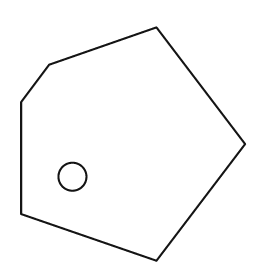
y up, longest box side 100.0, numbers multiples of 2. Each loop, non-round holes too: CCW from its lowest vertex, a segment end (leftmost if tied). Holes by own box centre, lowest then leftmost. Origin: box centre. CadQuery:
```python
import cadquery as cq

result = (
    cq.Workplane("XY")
    .moveTo(10.0, -50.0)
    .lineTo(48.0, 0.0)
    .lineTo(10.0, 50.0)
    .lineTo(-36.0, 34.0)
    .lineTo(-48.0, 18.0)
    .lineTo(-48.0, -30.0)
    .close()
    .moveTo(-26.0, -14.0)
    .circle(6.0)
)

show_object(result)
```